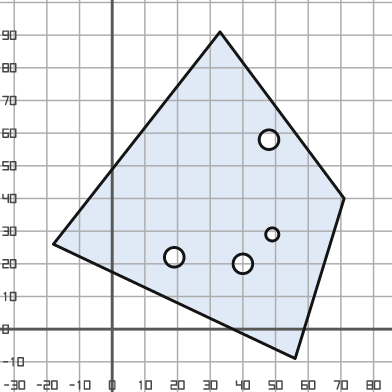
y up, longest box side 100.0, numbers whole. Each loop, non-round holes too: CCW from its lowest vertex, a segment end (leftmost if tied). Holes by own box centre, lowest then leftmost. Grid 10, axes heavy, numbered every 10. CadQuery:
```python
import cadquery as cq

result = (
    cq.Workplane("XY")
    .moveTo(56.0, -9.0)
    .lineTo(71.0, 40.0)
    .lineTo(33.0, 91.0)
    .lineTo(-18.0, 26.0)
    .close()
    .moveTo(40.0, 20.0)
    .circle(3.0)
    .moveTo(19.0, 22.0)
    .circle(3.0)
    .moveTo(49.0, 29.0)
    .circle(2.0)
    .moveTo(48.0, 58.0)
    .circle(3.0)
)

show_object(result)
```